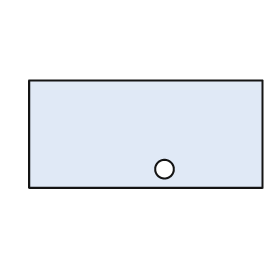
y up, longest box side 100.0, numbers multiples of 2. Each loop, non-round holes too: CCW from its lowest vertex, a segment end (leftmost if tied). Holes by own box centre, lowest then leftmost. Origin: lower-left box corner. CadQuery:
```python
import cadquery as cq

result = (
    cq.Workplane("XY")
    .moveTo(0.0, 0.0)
    .lineTo(100.0, 0.0)
    .lineTo(100.0, 46.0)
    .lineTo(0.0, 46.0)
    .close()
    .moveTo(58.0, 8.0)
    .circle(4.0)
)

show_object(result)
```